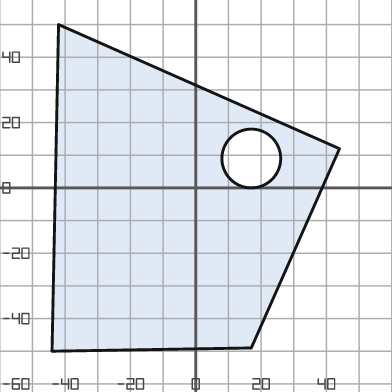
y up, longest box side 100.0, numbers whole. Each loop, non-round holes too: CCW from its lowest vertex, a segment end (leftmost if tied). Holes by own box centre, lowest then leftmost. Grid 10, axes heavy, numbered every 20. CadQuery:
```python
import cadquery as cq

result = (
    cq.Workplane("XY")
    .moveTo(-44.0, -50.0)
    .lineTo(17.0, -49.0)
    .lineTo(44.0, 12.0)
    .lineTo(-42.0, 50.0)
    .close()
    .moveTo(17.0, 9.0)
    .circle(9.0)
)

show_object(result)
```